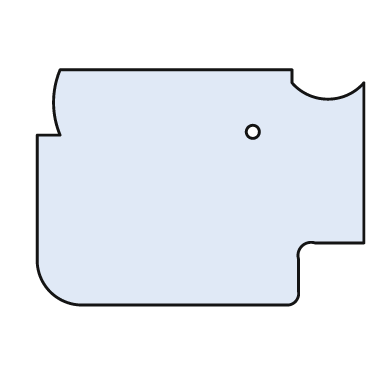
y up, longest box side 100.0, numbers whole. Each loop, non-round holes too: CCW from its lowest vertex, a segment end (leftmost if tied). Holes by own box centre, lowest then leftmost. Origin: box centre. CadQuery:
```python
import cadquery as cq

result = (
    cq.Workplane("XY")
    .moveTo(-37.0, -36.0)
    .lineTo(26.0, -36.0)
    .threePointArc((29.0, -35.0), (30.0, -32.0))
    .lineTo(30.0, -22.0)
    .threePointArc((31.0, -18.0), (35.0, -17.0))
    .lineTo(50.0, -17.0)
    .lineTo(50.0, 32.0)
    .threePointArc((39.0, 27.0), (28.0, 32.0))
    .lineTo(28.0, 36.0)
    .lineTo(-43.0, 36.0)
    .threePointArc((-45.0, 26.0), (-43.0, 16.0))
    .lineTo(-50.0, 16.0)
    .lineTo(-50.0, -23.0)
    .threePointArc((-46.0, -32.0), (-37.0, -36.0))
    .close()
    .moveTo(16.0, 17.0)
    .circle(2.0)
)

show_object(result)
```